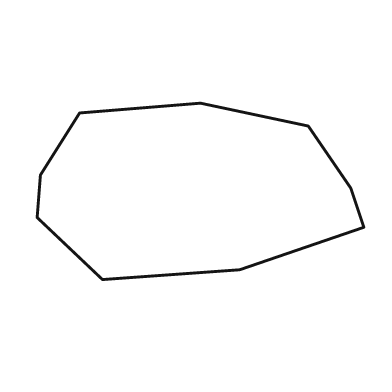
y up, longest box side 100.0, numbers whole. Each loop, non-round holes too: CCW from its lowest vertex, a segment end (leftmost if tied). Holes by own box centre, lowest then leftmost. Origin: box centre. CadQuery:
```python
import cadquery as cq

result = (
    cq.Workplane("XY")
    .moveTo(-30.0, -27.0)
    .lineTo(12.0, -24.0)
    .lineTo(50.0, -11.0)
    .lineTo(46.0, 1.0)
    .lineTo(33.0, 20.0)
    .lineTo(0.0, 27.0)
    .lineTo(-37.0, 24.0)
    .lineTo(-49.0, 5.0)
    .lineTo(-50.0, -8.0)
    .close()
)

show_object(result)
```